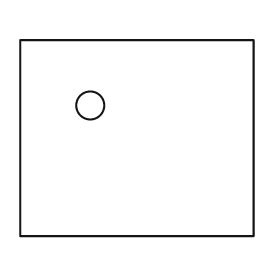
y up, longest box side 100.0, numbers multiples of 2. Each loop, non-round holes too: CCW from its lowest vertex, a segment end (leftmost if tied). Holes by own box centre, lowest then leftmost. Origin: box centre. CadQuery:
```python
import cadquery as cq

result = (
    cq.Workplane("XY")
    .moveTo(-50.0, -42.0)
    .lineTo(50.0, -42.0)
    .lineTo(50.0, 42.0)
    .lineTo(-50.0, 42.0)
    .close()
    .moveTo(-20.0, 14.0)
    .circle(6.0)
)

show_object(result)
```